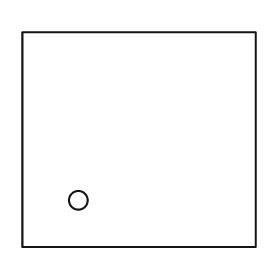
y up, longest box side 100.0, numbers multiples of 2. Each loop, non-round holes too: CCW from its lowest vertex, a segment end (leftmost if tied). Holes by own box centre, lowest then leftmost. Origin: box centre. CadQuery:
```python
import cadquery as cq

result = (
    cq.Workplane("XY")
    .moveTo(-50.0, -46.0)
    .lineTo(50.0, -46.0)
    .lineTo(50.0, 46.0)
    .lineTo(-50.0, 46.0)
    .close()
    .moveTo(-26.0, -26.0)
    .circle(4.0)
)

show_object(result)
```